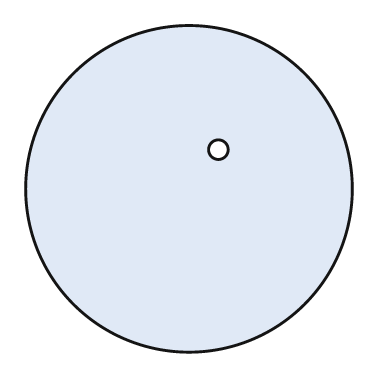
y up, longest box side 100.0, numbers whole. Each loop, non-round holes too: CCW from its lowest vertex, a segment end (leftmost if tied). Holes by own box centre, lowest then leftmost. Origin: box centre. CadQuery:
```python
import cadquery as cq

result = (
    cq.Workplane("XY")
    .moveTo(0.0, 0.0)
    .circle(50.0)
    .moveTo(9.0, 12.0)
    .circle(3.0)
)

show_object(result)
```